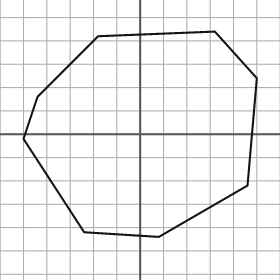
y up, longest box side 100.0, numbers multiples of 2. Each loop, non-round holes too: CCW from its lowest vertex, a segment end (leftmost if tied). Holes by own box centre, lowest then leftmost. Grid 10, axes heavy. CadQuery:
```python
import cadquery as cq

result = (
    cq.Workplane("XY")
    .moveTo(8.0, -44.0)
    .lineTo(46.0, -22.0)
    .lineTo(50.0, 24.0)
    .lineTo(32.0, 44.0)
    .lineTo(-18.0, 42.0)
    .lineTo(-44.0, 16.0)
    .lineTo(-50.0, -2.0)
    .lineTo(-24.0, -42.0)
    .close()
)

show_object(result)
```